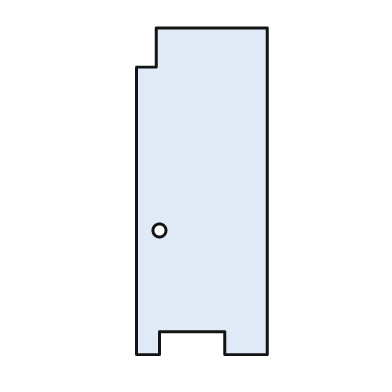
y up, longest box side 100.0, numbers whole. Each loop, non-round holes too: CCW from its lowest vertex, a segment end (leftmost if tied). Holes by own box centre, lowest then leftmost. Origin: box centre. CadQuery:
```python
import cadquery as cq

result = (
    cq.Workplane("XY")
    .moveTo(-20.0, -50.0)
    .lineTo(-13.0, -50.0)
    .lineTo(-13.0, -43.0)
    .lineTo(7.0, -43.0)
    .lineTo(7.0, -50.0)
    .lineTo(20.0, -50.0)
    .lineTo(20.0, 50.0)
    .lineTo(-14.0, 50.0)
    .lineTo(-14.0, 38.0)
    .lineTo(-20.0, 38.0)
    .close()
    .moveTo(-13.0, -12.0)
    .circle(2.0)
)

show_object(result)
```